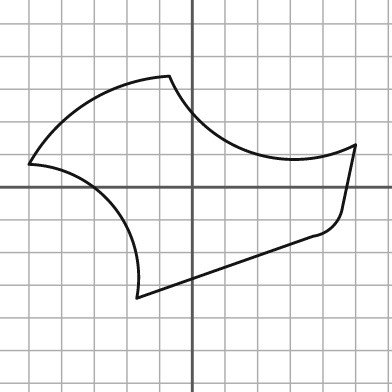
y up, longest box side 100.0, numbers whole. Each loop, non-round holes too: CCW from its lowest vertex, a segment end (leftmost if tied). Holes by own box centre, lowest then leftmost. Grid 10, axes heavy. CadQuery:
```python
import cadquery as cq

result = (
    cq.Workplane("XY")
    .moveTo(-17.0, -34.0)
    .lineTo(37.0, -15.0)
    .threePointArc((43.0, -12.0), (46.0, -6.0))
    .lineTo(50.0, 13.0)
    .threePointArc((17.0, 11.0), (-7.0, 34.0))
    .threePointArc((-32.0, 26.0), (-50.0, 7.0))
    .threePointArc((-24.0, -6.0), (-17.0, -34.0))
    .close()
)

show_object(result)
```